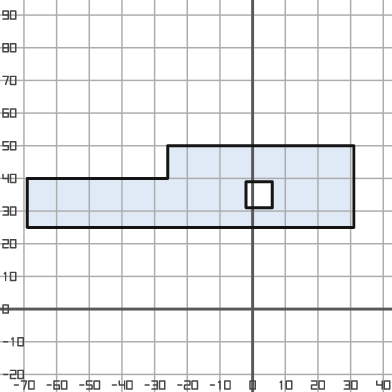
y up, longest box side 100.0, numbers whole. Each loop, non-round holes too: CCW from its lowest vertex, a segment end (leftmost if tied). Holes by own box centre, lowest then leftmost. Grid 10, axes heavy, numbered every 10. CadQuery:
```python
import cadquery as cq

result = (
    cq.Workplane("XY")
    .moveTo(-69.0, 25.0)
    .lineTo(31.0, 25.0)
    .lineTo(31.0, 50.0)
    .lineTo(-26.0, 50.0)
    .lineTo(-26.0, 40.0)
    .lineTo(-69.0, 40.0)
    .close()
    .moveTo(-2.0, 31.0)
    .lineTo(6.0, 31.0)
    .lineTo(6.0, 39.0)
    .lineTo(-2.0, 39.0)
    .close()
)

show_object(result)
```